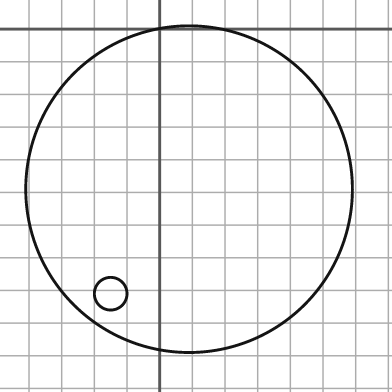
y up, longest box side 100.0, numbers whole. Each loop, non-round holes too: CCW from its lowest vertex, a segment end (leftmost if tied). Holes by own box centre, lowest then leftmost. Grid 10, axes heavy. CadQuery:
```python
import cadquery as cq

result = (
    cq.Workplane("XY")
    .moveTo(9.0, -49.0)
    .circle(50.0)
    .moveTo(-15.0, -81.0)
    .circle(5.0)
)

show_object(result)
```